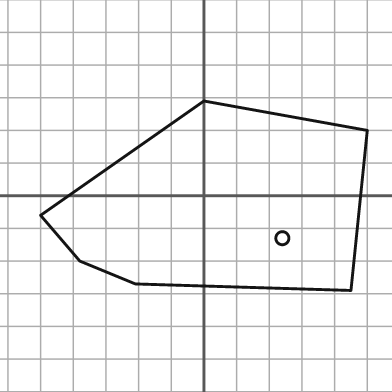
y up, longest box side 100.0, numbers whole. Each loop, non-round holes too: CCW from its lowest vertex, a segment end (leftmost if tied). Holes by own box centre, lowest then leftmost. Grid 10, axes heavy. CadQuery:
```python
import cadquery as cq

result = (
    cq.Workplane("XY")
    .moveTo(45.0, -29.0)
    .lineTo(50.0, 20.0)
    .lineTo(0.0, 29.0)
    .lineTo(-50.0, -6.0)
    .lineTo(-38.0, -20.0)
    .lineTo(-21.0, -27.0)
    .close()
    .moveTo(24.0, -13.0)
    .circle(2.0)
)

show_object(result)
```